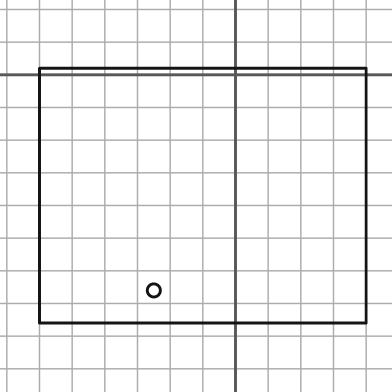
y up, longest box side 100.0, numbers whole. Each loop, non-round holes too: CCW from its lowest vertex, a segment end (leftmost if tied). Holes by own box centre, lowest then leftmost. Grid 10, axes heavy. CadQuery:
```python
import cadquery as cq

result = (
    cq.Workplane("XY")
    .moveTo(-60.0, -76.0)
    .lineTo(40.0, -76.0)
    .lineTo(40.0, 2.0)
    .lineTo(-60.0, 2.0)
    .close()
    .moveTo(-25.0, -66.0)
    .circle(2.0)
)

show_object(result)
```